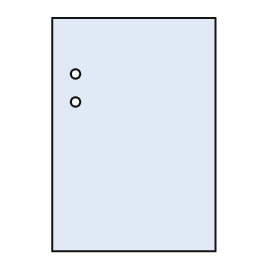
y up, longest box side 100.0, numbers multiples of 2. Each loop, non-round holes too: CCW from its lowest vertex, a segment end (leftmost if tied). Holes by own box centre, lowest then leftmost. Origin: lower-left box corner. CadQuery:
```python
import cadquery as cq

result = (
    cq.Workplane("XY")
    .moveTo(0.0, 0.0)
    .lineTo(70.0, 0.0)
    .lineTo(70.0, 100.0)
    .lineTo(0.0, 100.0)
    .close()
    .moveTo(10.0, 64.0)
    .circle(2.0)
    .moveTo(10.0, 76.0)
    .circle(2.0)
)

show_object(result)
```